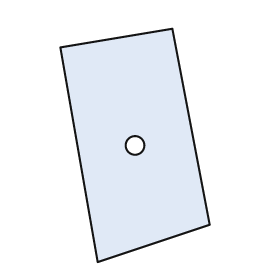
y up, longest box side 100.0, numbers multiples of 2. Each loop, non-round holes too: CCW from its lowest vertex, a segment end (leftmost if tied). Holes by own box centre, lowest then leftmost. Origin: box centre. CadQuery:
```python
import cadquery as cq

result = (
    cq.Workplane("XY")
    .moveTo(-16.0, -50.0)
    .lineTo(32.0, -34.0)
    .lineTo(16.0, 50.0)
    .lineTo(-32.0, 42.0)
    .close()
    .moveTo(0.0, 0.0)
    .circle(4.0)
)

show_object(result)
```